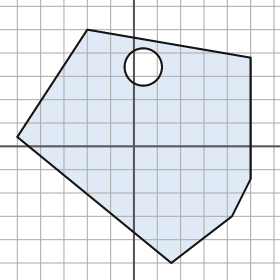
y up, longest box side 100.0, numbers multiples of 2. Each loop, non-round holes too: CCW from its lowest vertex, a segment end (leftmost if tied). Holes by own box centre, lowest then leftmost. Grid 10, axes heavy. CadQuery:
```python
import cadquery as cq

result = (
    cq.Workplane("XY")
    .moveTo(16.0, -50.0)
    .lineTo(42.0, -30.0)
    .lineTo(50.0, -14.0)
    .lineTo(50.0, 38.0)
    .lineTo(-20.0, 50.0)
    .lineTo(-50.0, 4.0)
    .close()
    .moveTo(4.0, 34.0)
    .circle(8.0)
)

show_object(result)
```